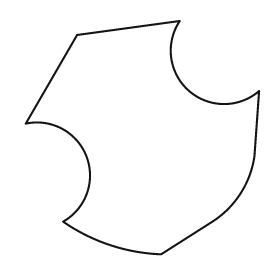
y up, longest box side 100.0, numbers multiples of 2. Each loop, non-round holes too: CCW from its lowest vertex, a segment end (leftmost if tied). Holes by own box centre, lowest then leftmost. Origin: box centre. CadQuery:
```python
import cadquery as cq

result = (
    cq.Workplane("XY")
    .moveTo(8.0, -50.0)
    .lineTo(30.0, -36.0)
    .threePointArc((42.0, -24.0), (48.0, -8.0))
    .lineTo(50.0, 20.0)
    .threePointArc((20.0, 20.0), (16.0, 50.0))
    .lineTo(-28.0, 44.0)
    .lineTo(-50.0, 6.0)
    .threePointArc((-24.0, -8.0), (-34.0, -36.0))
    .threePointArc((-14.0, -46.0), (8.0, -50.0))
    .close()
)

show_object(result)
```